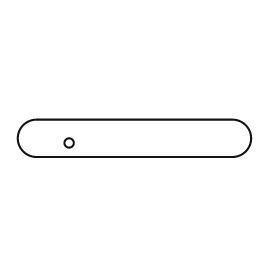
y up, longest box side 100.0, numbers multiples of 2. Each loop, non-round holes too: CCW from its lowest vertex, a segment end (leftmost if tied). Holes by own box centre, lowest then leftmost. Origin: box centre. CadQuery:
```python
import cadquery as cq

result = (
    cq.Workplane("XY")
    .moveTo(-42.0, -8.0)
    .lineTo(42.0, -8.0)
    .threePointArc((50.0, 0.0), (42.0, 8.0))
    .lineTo(-42.0, 8.0)
    .threePointArc((-50.0, 0.0), (-42.0, -8.0))
    .close()
    .moveTo(-28.0, -2.0)
    .circle(2.0)
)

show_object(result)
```